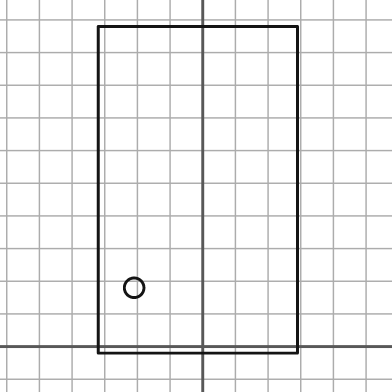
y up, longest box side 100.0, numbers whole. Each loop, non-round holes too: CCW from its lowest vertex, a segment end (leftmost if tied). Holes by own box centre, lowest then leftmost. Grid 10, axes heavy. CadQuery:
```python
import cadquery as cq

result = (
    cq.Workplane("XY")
    .moveTo(-32.0, -2.0)
    .lineTo(29.0, -2.0)
    .lineTo(29.0, 98.0)
    .lineTo(-32.0, 98.0)
    .close()
    .moveTo(-21.0, 18.0)
    .circle(3.0)
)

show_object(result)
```